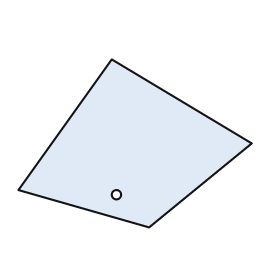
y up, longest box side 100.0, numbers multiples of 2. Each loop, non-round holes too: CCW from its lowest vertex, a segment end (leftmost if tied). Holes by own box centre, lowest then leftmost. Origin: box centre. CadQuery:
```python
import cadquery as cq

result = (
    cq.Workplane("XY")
    .moveTo(6.0, -36.0)
    .lineTo(50.0, 0.0)
    .lineTo(-10.0, 36.0)
    .lineTo(-50.0, -20.0)
    .close()
    .moveTo(-8.0, -22.0)
    .circle(2.0)
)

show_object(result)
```